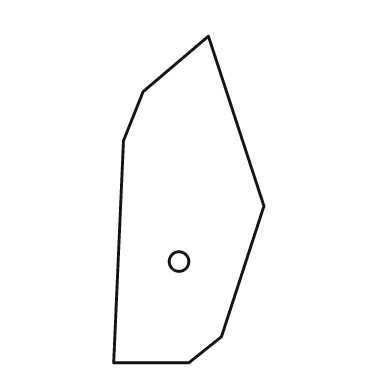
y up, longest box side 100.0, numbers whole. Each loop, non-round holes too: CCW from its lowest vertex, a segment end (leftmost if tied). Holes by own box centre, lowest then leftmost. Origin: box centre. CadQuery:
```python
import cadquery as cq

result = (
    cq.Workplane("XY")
    .moveTo(-23.0, -50.0)
    .lineTo(0.0, -50.0)
    .lineTo(10.0, -42.0)
    .lineTo(23.0, -2.0)
    .lineTo(6.0, 50.0)
    .lineTo(-14.0, 33.0)
    .lineTo(-20.0, 18.0)
    .close()
    .moveTo(-3.0, -19.0)
    .circle(3.0)
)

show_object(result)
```